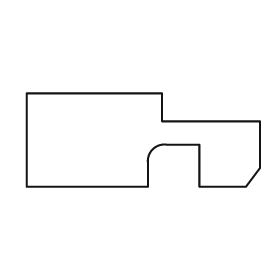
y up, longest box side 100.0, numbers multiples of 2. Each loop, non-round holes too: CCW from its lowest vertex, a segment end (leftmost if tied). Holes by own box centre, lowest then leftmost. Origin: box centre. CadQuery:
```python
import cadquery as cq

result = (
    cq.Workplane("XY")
    .moveTo(-50.0, -20.0)
    .lineTo(2.0, -20.0)
    .lineTo(2.0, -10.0)
    .threePointArc((4.0, -4.0), (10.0, -2.0))
    .lineTo(24.0, -2.0)
    .lineTo(24.0, -20.0)
    .lineTo(44.0, -20.0)
    .lineTo(50.0, -12.0)
    .lineTo(50.0, 8.0)
    .lineTo(8.0, 8.0)
    .lineTo(8.0, 20.0)
    .lineTo(-50.0, 20.0)
    .close()
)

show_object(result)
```